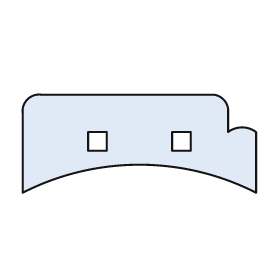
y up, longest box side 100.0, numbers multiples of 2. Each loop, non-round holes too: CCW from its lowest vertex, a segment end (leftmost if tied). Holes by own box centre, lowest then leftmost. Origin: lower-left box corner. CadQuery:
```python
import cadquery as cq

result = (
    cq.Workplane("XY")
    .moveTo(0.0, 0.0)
    .threePointArc((50.0, 12.0), (100.0, 0.0))
    .lineTo(100.0, 26.0)
    .threePointArc((94.0, 28.0), (88.0, 26.0))
    .lineTo(88.0, 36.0)
    .threePointArc((86.0, 40.0), (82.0, 42.0))
    .lineTo(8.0, 42.0)
    .threePointArc((2.0, 40.0), (0.0, 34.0))
    .close()
    .moveTo(28.0, 18.0)
    .lineTo(36.0, 18.0)
    .lineTo(36.0, 26.0)
    .lineTo(28.0, 26.0)
    .close()
    .moveTo(64.0, 18.0)
    .lineTo(72.0, 18.0)
    .lineTo(72.0, 26.0)
    .lineTo(64.0, 26.0)
    .close()
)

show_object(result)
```